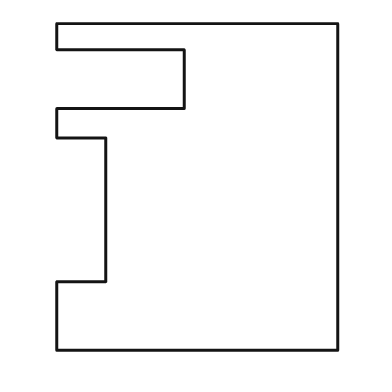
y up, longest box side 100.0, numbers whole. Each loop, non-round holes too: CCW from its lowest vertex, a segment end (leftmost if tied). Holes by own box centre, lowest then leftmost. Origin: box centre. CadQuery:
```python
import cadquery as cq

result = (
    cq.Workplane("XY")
    .moveTo(-43.0, -50.0)
    .lineTo(43.0, -50.0)
    .lineTo(43.0, 50.0)
    .lineTo(-43.0, 50.0)
    .lineTo(-43.0, 42.0)
    .lineTo(-4.0, 42.0)
    .lineTo(-4.0, 24.0)
    .lineTo(-43.0, 24.0)
    .lineTo(-43.0, 15.0)
    .lineTo(-28.0, 15.0)
    .lineTo(-28.0, -29.0)
    .lineTo(-43.0, -29.0)
    .close()
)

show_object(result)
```